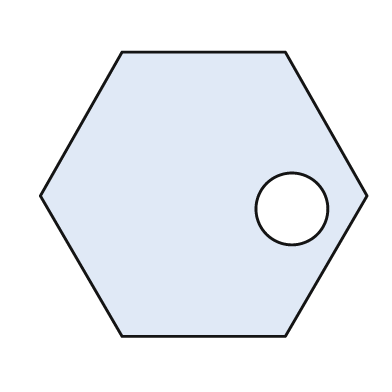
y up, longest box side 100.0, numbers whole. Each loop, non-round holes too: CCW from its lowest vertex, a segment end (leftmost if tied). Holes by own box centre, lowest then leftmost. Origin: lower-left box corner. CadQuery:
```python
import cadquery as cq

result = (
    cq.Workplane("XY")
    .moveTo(25.0, 0.0)
    .lineTo(75.0, 0.0)
    .lineTo(100.0, 43.0)
    .lineTo(75.0, 87.0)
    .lineTo(25.0, 87.0)
    .lineTo(0.0, 43.0)
    .close()
    .moveTo(77.0, 39.0)
    .circle(11.0)
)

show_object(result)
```